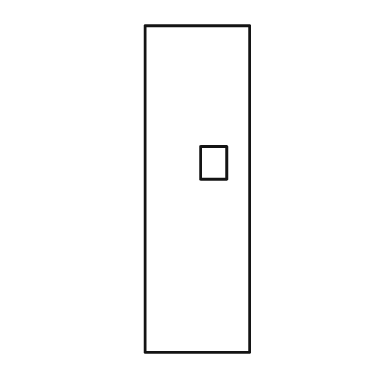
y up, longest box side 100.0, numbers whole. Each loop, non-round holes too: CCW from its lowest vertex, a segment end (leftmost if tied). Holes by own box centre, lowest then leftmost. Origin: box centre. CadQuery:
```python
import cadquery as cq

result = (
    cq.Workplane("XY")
    .moveTo(-16.0, -50.0)
    .lineTo(16.0, -50.0)
    .lineTo(16.0, 50.0)
    .lineTo(-16.0, 50.0)
    .close()
    .moveTo(1.0, 3.0)
    .lineTo(9.0, 3.0)
    .lineTo(9.0, 13.0)
    .lineTo(1.0, 13.0)
    .close()
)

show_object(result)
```